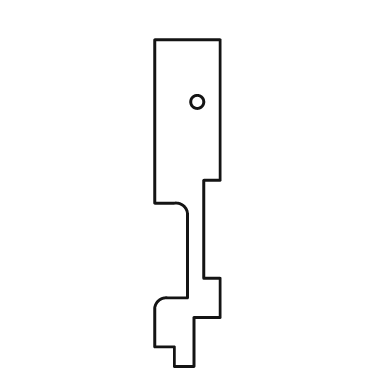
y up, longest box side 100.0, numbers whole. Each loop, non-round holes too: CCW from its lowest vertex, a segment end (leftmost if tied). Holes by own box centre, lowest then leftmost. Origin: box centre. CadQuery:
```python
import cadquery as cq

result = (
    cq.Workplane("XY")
    .moveTo(-4.0, -50.0)
    .lineTo(2.0, -50.0)
    .lineTo(2.0, -35.0)
    .lineTo(10.0, -35.0)
    .lineTo(10.0, -23.0)
    .lineTo(5.0, -23.0)
    .lineTo(5.0, 7.0)
    .lineTo(10.0, 7.0)
    .lineTo(10.0, 50.0)
    .lineTo(-10.0, 50.0)
    .lineTo(-10.0, 0.0)
    .lineTo(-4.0, 0.0)
    .threePointArc((-1.0, -1.0), (0.0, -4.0))
    .lineTo(0.0, -29.0)
    .lineTo(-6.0, -29.0)
    .threePointArc((-9.0, -30.0), (-10.0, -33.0))
    .lineTo(-10.0, -44.0)
    .lineTo(-4.0, -44.0)
    .close()
    .moveTo(3.0, 31.0)
    .circle(2.0)
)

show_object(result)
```